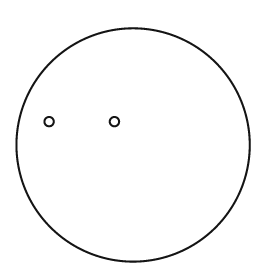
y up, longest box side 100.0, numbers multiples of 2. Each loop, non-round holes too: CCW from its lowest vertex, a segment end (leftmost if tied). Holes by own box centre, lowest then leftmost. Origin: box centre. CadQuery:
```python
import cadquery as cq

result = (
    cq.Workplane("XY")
    .moveTo(0.0, 0.0)
    .circle(50.0)
    .moveTo(-36.0, 10.0)
    .circle(2.0)
    .moveTo(-8.0, 10.0)
    .circle(2.0)
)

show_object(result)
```